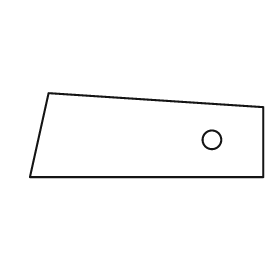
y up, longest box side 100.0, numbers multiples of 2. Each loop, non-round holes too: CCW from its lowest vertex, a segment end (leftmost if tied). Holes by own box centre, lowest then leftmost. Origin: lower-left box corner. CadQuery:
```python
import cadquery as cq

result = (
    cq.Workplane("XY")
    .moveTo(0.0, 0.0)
    .lineTo(100.0, 0.0)
    .lineTo(100.0, 30.0)
    .lineTo(8.0, 36.0)
    .close()
    .moveTo(78.0, 16.0)
    .circle(4.0)
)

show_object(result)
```